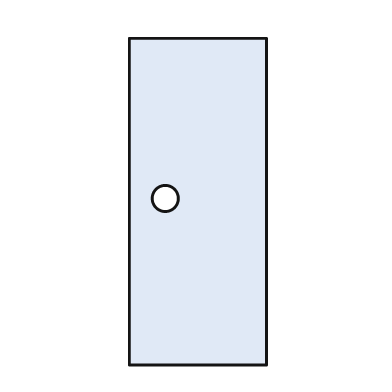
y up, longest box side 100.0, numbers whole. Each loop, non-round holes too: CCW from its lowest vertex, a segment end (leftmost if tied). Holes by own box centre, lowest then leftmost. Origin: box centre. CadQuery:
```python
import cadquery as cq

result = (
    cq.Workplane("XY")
    .moveTo(-21.0, -50.0)
    .lineTo(21.0, -50.0)
    .lineTo(21.0, 50.0)
    .lineTo(-21.0, 50.0)
    .close()
    .moveTo(-10.0, 1.0)
    .circle(4.0)
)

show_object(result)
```